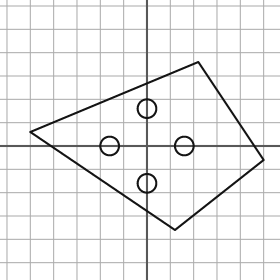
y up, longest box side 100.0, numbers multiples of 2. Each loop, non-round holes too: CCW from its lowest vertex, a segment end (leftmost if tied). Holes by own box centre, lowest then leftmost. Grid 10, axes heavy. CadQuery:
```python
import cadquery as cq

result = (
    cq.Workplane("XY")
    .moveTo(12.0, -36.0)
    .lineTo(50.0, -6.0)
    .lineTo(22.0, 36.0)
    .lineTo(-50.0, 6.0)
    .close()
    .moveTo(0.0, -16.0)
    .circle(4.0)
    .moveTo(-16.0, 0.0)
    .circle(4.0)
    .moveTo(16.0, 0.0)
    .circle(4.0)
    .moveTo(0.0, 16.0)
    .circle(4.0)
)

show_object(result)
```